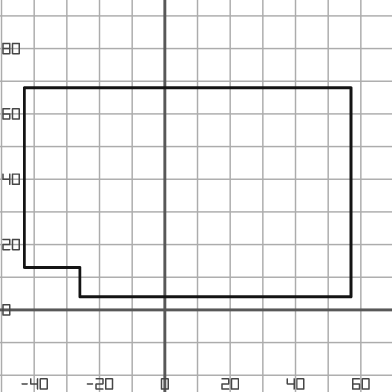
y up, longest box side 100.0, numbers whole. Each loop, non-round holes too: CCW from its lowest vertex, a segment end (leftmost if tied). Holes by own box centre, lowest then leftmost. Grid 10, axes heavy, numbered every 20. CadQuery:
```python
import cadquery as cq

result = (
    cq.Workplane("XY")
    .moveTo(-26.0, 4.0)
    .lineTo(57.0, 4.0)
    .lineTo(57.0, 68.0)
    .lineTo(-43.0, 68.0)
    .lineTo(-43.0, 13.0)
    .lineTo(-26.0, 13.0)
    .close()
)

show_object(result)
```